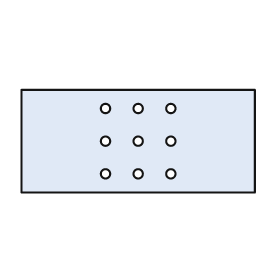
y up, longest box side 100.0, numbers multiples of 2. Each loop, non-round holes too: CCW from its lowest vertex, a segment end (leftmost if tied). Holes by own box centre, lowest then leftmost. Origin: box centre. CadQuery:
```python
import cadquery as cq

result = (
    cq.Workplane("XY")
    .moveTo(-50.0, -22.0)
    .lineTo(50.0, -22.0)
    .lineTo(50.0, 22.0)
    .lineTo(-50.0, 22.0)
    .close()
    .moveTo(-14.0, -14.0)
    .circle(2.0)
    .moveTo(0.0, -14.0)
    .circle(2.0)
    .moveTo(14.0, -14.0)
    .circle(2.0)
    .moveTo(-14.0, 0.0)
    .circle(2.0)
    .moveTo(0.0, 0.0)
    .circle(2.0)
    .moveTo(14.0, 0.0)
    .circle(2.0)
    .moveTo(-14.0, 14.0)
    .circle(2.0)
    .moveTo(0.0, 14.0)
    .circle(2.0)
    .moveTo(14.0, 14.0)
    .circle(2.0)
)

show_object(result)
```